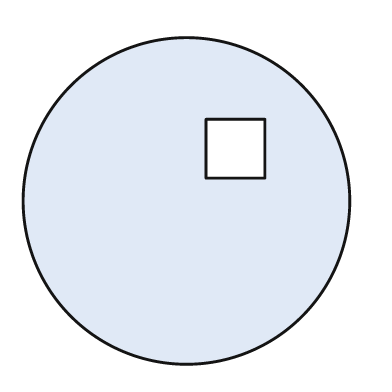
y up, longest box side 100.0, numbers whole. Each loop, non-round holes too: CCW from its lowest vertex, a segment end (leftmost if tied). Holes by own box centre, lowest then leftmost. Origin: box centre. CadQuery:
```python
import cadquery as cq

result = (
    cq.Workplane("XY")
    .moveTo(0.0, 0.0)
    .circle(50.0)
    .moveTo(6.0, 7.0)
    .lineTo(24.0, 7.0)
    .lineTo(24.0, 25.0)
    .lineTo(6.0, 25.0)
    .close()
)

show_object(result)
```